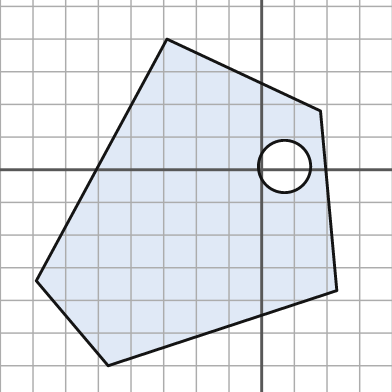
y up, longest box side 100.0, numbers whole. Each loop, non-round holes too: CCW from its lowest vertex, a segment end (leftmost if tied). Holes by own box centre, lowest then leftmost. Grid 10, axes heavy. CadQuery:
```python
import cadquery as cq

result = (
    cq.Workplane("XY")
    .moveTo(-47.0, -60.0)
    .lineTo(23.0, -37.0)
    .lineTo(18.0, 18.0)
    .lineTo(-29.0, 40.0)
    .lineTo(-69.0, -34.0)
    .close()
    .moveTo(7.0, 1.0)
    .circle(8.0)
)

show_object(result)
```